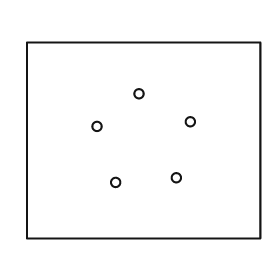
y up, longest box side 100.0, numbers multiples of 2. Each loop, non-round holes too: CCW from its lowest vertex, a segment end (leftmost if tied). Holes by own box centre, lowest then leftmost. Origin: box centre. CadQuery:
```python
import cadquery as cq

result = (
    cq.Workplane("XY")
    .moveTo(-50.0, -42.0)
    .lineTo(50.0, -42.0)
    .lineTo(50.0, 42.0)
    .lineTo(-50.0, 42.0)
    .close()
    .moveTo(-12.0, -18.0)
    .circle(2.0)
    .moveTo(14.0, -16.0)
    .circle(2.0)
    .moveTo(-20.0, 6.0)
    .circle(2.0)
    .moveTo(20.0, 8.0)
    .circle(2.0)
    .moveTo(-2.0, 20.0)
    .circle(2.0)
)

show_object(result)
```